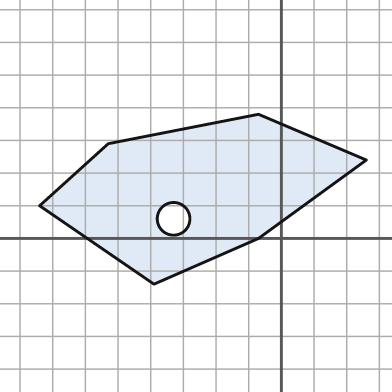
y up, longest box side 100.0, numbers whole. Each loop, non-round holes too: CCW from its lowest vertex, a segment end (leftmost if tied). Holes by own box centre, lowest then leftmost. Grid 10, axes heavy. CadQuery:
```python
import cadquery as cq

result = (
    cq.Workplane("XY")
    .moveTo(-39.0, -14.0)
    .lineTo(-7.0, 0.0)
    .lineTo(26.0, 24.0)
    .lineTo(-7.0, 38.0)
    .lineTo(-53.0, 29.0)
    .lineTo(-74.0, 10.0)
    .close()
    .moveTo(-33.0, 6.0)
    .circle(5.0)
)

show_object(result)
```